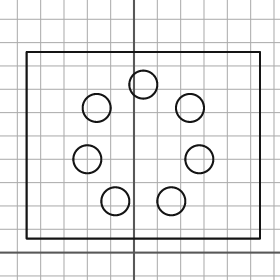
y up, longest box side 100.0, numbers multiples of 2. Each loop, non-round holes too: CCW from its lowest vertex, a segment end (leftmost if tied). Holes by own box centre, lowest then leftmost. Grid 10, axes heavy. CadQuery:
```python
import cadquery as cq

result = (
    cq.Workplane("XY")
    .moveTo(-46.0, 6.0)
    .lineTo(54.0, 6.0)
    .lineTo(54.0, 86.0)
    .lineTo(-46.0, 86.0)
    .close()
    .moveTo(-8.0, 22.0)
    .circle(6.0)
    .moveTo(16.0, 22.0)
    .circle(6.0)
    .moveTo(-20.0, 40.0)
    .circle(6.0)
    .moveTo(28.0, 40.0)
    .circle(6.0)
    .moveTo(-16.0, 62.0)
    .circle(6.0)
    .moveTo(24.0, 62.0)
    .circle(6.0)
    .moveTo(4.0, 72.0)
    .circle(6.0)
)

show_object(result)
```